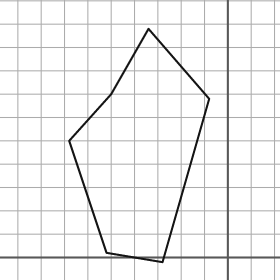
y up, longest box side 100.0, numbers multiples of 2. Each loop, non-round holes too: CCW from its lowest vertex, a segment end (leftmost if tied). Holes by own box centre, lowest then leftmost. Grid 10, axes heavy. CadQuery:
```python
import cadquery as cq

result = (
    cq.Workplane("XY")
    .moveTo(-28.0, -2.0)
    .lineTo(-8.0, 68.0)
    .lineTo(-34.0, 98.0)
    .lineTo(-50.0, 70.0)
    .lineTo(-68.0, 50.0)
    .lineTo(-52.0, 2.0)
    .close()
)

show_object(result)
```